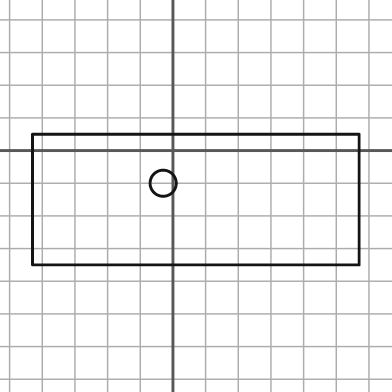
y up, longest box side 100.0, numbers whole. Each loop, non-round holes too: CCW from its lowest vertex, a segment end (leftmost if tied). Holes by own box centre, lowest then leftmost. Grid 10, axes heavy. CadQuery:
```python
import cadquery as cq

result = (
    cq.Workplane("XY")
    .moveTo(-43.0, -35.0)
    .lineTo(57.0, -35.0)
    .lineTo(57.0, 5.0)
    .lineTo(-43.0, 5.0)
    .close()
    .moveTo(-3.0, -10.0)
    .circle(4.0)
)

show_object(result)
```